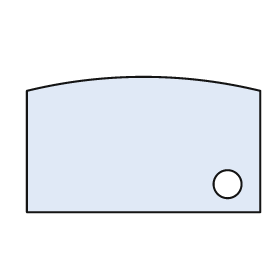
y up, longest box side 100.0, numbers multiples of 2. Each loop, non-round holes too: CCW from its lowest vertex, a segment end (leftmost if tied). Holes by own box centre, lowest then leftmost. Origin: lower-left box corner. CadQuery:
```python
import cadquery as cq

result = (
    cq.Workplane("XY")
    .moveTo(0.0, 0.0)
    .lineTo(100.0, 0.0)
    .lineTo(100.0, 52.0)
    .threePointArc((50.0, 58.0), (0.0, 52.0))
    .close()
    .moveTo(86.0, 12.0)
    .circle(6.0)
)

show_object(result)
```